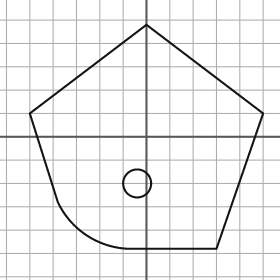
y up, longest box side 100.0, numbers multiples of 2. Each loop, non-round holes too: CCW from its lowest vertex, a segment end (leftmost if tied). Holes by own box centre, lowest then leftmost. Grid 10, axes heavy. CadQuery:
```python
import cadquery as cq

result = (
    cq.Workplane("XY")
    .moveTo(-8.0, -48.0)
    .lineTo(30.0, -48.0)
    .lineTo(50.0, 10.0)
    .lineTo(0.0, 48.0)
    .lineTo(-50.0, 10.0)
    .lineTo(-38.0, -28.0)
    .threePointArc((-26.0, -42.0), (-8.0, -48.0))
    .close()
    .moveTo(-4.0, -20.0)
    .circle(6.0)
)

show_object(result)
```